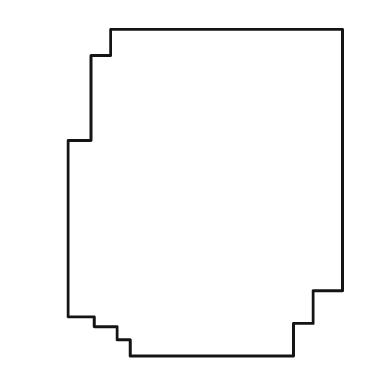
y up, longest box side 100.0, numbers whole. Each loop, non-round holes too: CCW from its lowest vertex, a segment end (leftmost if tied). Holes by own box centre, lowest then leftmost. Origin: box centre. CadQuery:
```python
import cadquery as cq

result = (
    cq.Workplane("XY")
    .moveTo(-23.0, -50.0)
    .lineTo(27.0, -50.0)
    .lineTo(27.0, -40.0)
    .lineTo(33.0, -40.0)
    .lineTo(33.0, -30.0)
    .lineTo(42.0, -30.0)
    .lineTo(42.0, 50.0)
    .lineTo(-29.0, 50.0)
    .lineTo(-29.0, 42.0)
    .lineTo(-35.0, 42.0)
    .lineTo(-35.0, 16.0)
    .lineTo(-42.0, 16.0)
    .lineTo(-42.0, -38.0)
    .lineTo(-34.0, -38.0)
    .lineTo(-34.0, -41.0)
    .lineTo(-27.0, -41.0)
    .lineTo(-27.0, -45.0)
    .lineTo(-23.0, -45.0)
    .close()
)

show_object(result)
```